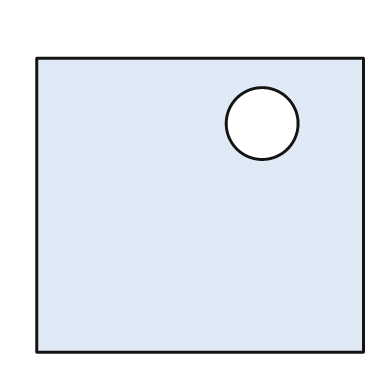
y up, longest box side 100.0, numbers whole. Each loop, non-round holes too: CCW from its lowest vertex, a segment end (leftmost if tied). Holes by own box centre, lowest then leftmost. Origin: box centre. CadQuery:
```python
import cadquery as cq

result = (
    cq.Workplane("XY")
    .moveTo(-50.0, -45.0)
    .lineTo(50.0, -45.0)
    .lineTo(50.0, 45.0)
    .lineTo(-50.0, 45.0)
    .close()
    .moveTo(19.0, 25.0)
    .circle(11.0)
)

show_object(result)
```